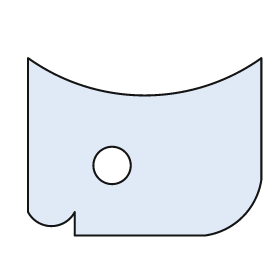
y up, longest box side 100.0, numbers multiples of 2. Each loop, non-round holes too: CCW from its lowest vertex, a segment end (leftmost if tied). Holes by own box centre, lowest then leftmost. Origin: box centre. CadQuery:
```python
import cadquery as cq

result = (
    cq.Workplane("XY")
    .moveTo(-30.0, -38.0)
    .lineTo(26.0, -38.0)
    .threePointArc((42.0, -30.0), (50.0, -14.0))
    .lineTo(50.0, 38.0)
    .threePointArc((0.0, 22.0), (-50.0, 38.0))
    .lineTo(-50.0, -28.0)
    .threePointArc((-40.0, -34.0), (-30.0, -28.0))
    .close()
    .moveTo(-14.0, -8.0)
    .circle(8.0)
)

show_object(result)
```